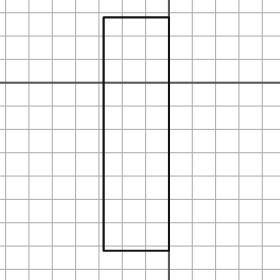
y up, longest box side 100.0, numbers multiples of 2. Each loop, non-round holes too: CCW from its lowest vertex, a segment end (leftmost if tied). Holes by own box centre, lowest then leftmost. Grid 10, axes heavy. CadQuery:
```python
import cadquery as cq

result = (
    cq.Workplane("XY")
    .moveTo(-28.0, -72.0)
    .lineTo(0.0, -72.0)
    .lineTo(0.0, 28.0)
    .lineTo(-28.0, 28.0)
    .close()
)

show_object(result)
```